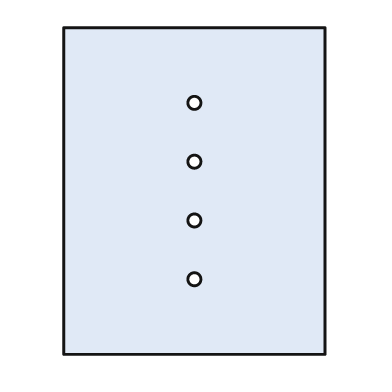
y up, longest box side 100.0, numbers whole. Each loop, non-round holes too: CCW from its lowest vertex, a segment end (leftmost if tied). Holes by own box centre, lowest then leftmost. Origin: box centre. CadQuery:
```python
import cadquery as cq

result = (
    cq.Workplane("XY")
    .moveTo(-40.0, -50.0)
    .lineTo(40.0, -50.0)
    .lineTo(40.0, 50.0)
    .lineTo(-40.0, 50.0)
    .close()
    .moveTo(0.0, -27.0)
    .circle(2.0)
    .moveTo(0.0, -9.0)
    .circle(2.0)
    .moveTo(0.0, 9.0)
    .circle(2.0)
    .moveTo(0.0, 27.0)
    .circle(2.0)
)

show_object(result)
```